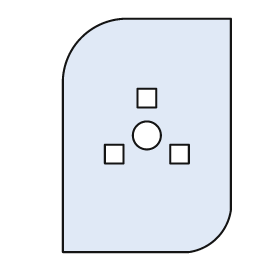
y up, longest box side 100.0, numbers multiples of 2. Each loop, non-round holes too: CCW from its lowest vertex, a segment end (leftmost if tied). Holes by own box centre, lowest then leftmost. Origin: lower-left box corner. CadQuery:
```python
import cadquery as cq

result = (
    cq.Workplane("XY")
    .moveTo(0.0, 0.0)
    .lineTo(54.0, 0.0)
    .threePointArc((66.0, 6.0), (72.0, 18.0))
    .lineTo(72.0, 100.0)
    .lineTo(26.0, 100.0)
    .threePointArc((8.0, 92.0), (0.0, 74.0))
    .close()
    .moveTo(18.0, 38.0)
    .lineTo(26.0, 38.0)
    .lineTo(26.0, 46.0)
    .lineTo(18.0, 46.0)
    .close()
    .moveTo(46.0, 38.0)
    .lineTo(54.0, 38.0)
    .lineTo(54.0, 46.0)
    .lineTo(46.0, 46.0)
    .close()
    .moveTo(36.0, 50.0)
    .circle(6.0)
    .moveTo(32.0, 62.0)
    .lineTo(40.0, 62.0)
    .lineTo(40.0, 70.0)
    .lineTo(32.0, 70.0)
    .close()
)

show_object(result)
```